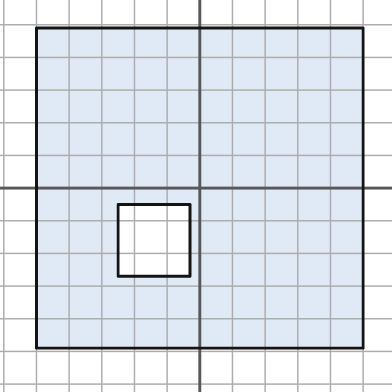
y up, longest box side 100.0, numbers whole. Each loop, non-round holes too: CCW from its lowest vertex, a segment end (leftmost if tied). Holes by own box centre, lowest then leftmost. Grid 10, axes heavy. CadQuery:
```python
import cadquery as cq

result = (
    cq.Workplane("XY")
    .moveTo(-50.0, -49.0)
    .lineTo(50.0, -49.0)
    .lineTo(50.0, 49.0)
    .lineTo(-50.0, 49.0)
    .close()
    .moveTo(-25.0, -27.0)
    .lineTo(-3.0, -27.0)
    .lineTo(-3.0, -5.0)
    .lineTo(-25.0, -5.0)
    .close()
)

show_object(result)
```